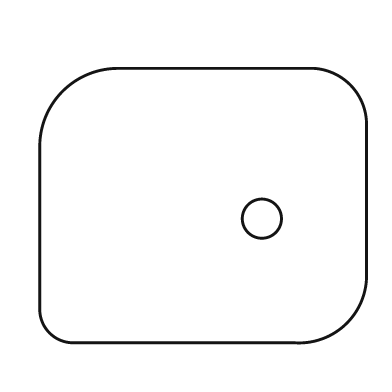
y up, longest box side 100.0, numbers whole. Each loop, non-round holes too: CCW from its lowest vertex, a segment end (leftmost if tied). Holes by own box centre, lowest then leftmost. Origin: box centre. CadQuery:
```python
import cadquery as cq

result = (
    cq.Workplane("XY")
    .moveTo(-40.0, -42.0)
    .lineTo(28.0, -42.0)
    .threePointArc((44.0, -36.0), (50.0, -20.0))
    .lineTo(50.0, 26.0)
    .threePointArc((45.0, 37.0), (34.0, 42.0))
    .lineTo(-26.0, 42.0)
    .threePointArc((-43.0, 35.0), (-50.0, 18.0))
    .lineTo(-50.0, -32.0)
    .threePointArc((-47.0, -39.0), (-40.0, -42.0))
    .close()
    .moveTo(18.0, -4.0)
    .circle(6.0)
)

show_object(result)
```